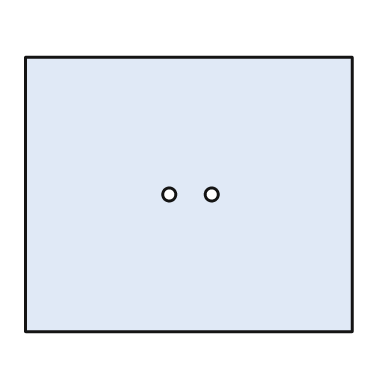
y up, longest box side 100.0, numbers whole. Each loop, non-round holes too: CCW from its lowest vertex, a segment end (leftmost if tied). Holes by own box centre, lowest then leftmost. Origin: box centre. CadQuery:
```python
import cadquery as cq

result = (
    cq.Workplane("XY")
    .moveTo(-50.0, -42.0)
    .lineTo(50.0, -42.0)
    .lineTo(50.0, 42.0)
    .lineTo(-50.0, 42.0)
    .close()
    .moveTo(-6.0, 0.0)
    .circle(2.0)
    .moveTo(7.0, 0.0)
    .circle(2.0)
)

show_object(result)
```